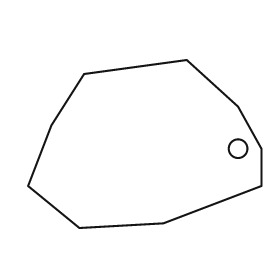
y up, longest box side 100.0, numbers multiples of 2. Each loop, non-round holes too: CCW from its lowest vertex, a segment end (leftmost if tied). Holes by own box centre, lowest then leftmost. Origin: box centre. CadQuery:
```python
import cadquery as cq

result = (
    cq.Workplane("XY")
    .moveTo(-28.0, -36.0)
    .lineTo(8.0, -34.0)
    .lineTo(50.0, -18.0)
    .lineTo(50.0, -2.0)
    .lineTo(40.0, 16.0)
    .lineTo(18.0, 36.0)
    .lineTo(-26.0, 30.0)
    .lineTo(-40.0, 8.0)
    .lineTo(-50.0, -18.0)
    .close()
    .moveTo(40.0, -2.0)
    .circle(4.0)
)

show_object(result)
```